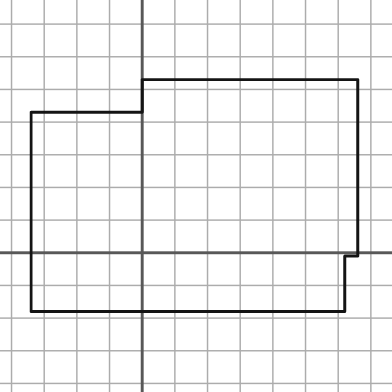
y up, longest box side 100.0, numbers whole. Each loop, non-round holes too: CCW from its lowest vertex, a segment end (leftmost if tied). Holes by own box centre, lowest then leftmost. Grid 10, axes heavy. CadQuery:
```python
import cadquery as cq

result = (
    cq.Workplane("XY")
    .moveTo(-34.0, -18.0)
    .lineTo(62.0, -18.0)
    .lineTo(62.0, -1.0)
    .lineTo(66.0, -1.0)
    .lineTo(66.0, 53.0)
    .lineTo(0.0, 53.0)
    .lineTo(0.0, 43.0)
    .lineTo(-34.0, 43.0)
    .close()
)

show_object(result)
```